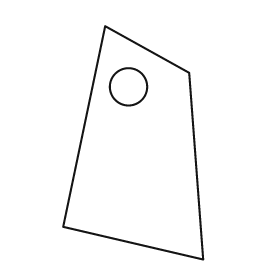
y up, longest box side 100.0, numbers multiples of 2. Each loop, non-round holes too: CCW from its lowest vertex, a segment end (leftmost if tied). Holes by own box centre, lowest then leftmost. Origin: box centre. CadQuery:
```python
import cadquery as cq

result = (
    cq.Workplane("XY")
    .moveTo(30.0, -50.0)
    .lineTo(24.0, 30.0)
    .lineTo(-12.0, 50.0)
    .lineTo(-30.0, -36.0)
    .close()
    .moveTo(-2.0, 24.0)
    .circle(8.0)
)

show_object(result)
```